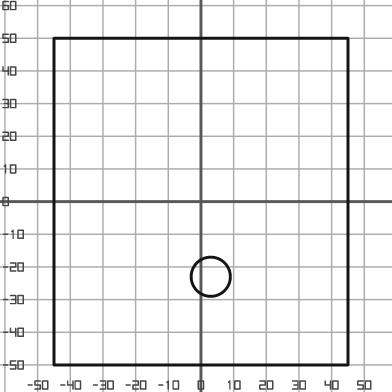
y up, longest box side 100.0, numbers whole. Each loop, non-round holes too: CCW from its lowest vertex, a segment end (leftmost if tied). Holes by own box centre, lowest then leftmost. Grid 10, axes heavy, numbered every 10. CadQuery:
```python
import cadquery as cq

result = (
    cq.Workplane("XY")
    .moveTo(-45.0, -50.0)
    .lineTo(45.0, -50.0)
    .lineTo(45.0, 50.0)
    .lineTo(-45.0, 50.0)
    .close()
    .moveTo(3.0, -23.0)
    .circle(6.0)
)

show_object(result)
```